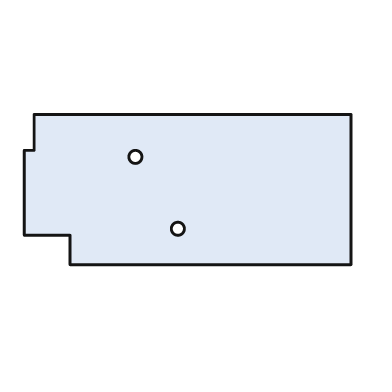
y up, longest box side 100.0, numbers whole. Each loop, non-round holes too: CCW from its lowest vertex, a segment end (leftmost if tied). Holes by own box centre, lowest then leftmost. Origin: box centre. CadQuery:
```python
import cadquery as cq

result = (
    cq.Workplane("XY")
    .moveTo(-36.0, -23.0)
    .lineTo(50.0, -23.0)
    .lineTo(50.0, 23.0)
    .lineTo(-47.0, 23.0)
    .lineTo(-47.0, 12.0)
    .lineTo(-50.0, 12.0)
    .lineTo(-50.0, -14.0)
    .lineTo(-36.0, -14.0)
    .close()
    .moveTo(-3.0, -12.0)
    .circle(2.0)
    .moveTo(-16.0, 10.0)
    .circle(2.0)
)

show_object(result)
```